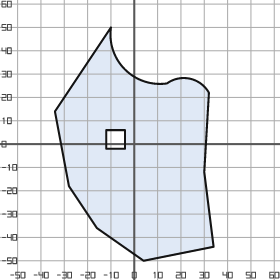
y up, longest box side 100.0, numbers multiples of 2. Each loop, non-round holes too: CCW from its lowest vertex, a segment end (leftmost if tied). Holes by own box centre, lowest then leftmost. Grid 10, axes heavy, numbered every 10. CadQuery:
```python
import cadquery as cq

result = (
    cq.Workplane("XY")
    .moveTo(4.0, -50.0)
    .lineTo(34.0, -44.0)
    .lineTo(30.0, -12.0)
    .lineTo(32.0, 22.0)
    .threePointArc((24.0, 28.0), (14.0, 26.0))
    .threePointArc((-4.0, 32.0), (-10.0, 50.0))
    .lineTo(-34.0, 14.0)
    .lineTo(-28.0, -18.0)
    .lineTo(-16.0, -36.0)
    .close()
    .moveTo(-12.0, -2.0)
    .lineTo(-4.0, -2.0)
    .lineTo(-4.0, 6.0)
    .lineTo(-12.0, 6.0)
    .close()
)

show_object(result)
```